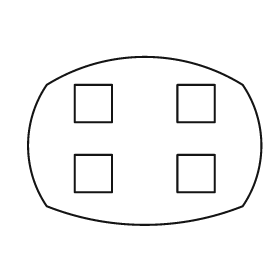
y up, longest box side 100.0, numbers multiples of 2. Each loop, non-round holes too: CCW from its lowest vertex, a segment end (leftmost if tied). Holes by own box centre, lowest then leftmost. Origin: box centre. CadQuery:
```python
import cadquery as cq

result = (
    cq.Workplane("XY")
    .moveTo(-42.0, -28.0)
    .threePointArc((0.0, -36.0), (42.0, -28.0))
    .threePointArc((50.0, -2.0), (42.0, 24.0))
    .threePointArc((0.0, 36.0), (-42.0, 24.0))
    .threePointArc((-50.0, -2.0), (-42.0, -28.0))
    .close()
    .moveTo(-30.0, -22.0)
    .lineTo(-14.0, -22.0)
    .lineTo(-14.0, -6.0)
    .lineTo(-30.0, -6.0)
    .close()
    .moveTo(14.0, -22.0)
    .lineTo(30.0, -22.0)
    .lineTo(30.0, -6.0)
    .lineTo(14.0, -6.0)
    .close()
    .moveTo(-30.0, 8.0)
    .lineTo(-14.0, 8.0)
    .lineTo(-14.0, 24.0)
    .lineTo(-30.0, 24.0)
    .close()
    .moveTo(14.0, 8.0)
    .lineTo(30.0, 8.0)
    .lineTo(30.0, 24.0)
    .lineTo(14.0, 24.0)
    .close()
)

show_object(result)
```